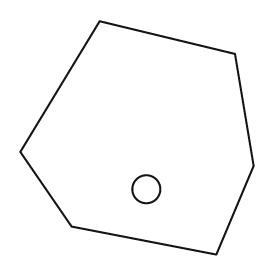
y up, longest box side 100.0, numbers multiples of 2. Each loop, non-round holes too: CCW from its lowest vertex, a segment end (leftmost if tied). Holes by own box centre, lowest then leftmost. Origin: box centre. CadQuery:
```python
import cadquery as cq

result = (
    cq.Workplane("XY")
    .moveTo(34.0, -50.0)
    .lineTo(50.0, -12.0)
    .lineTo(42.0, 36.0)
    .lineTo(-16.0, 50.0)
    .lineTo(-50.0, -6.0)
    .lineTo(-28.0, -38.0)
    .close()
    .moveTo(4.0, -22.0)
    .circle(6.0)
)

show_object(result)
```